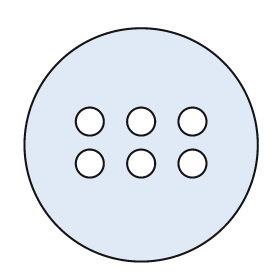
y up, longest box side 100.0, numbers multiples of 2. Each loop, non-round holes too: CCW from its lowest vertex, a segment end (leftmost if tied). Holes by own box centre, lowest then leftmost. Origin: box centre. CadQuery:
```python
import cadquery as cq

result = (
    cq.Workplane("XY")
    .moveTo(0.0, 0.0)
    .circle(50.0)
    .moveTo(-22.0, -8.0)
    .circle(6.0)
    .moveTo(0.0, -8.0)
    .circle(6.0)
    .moveTo(22.0, -8.0)
    .circle(6.0)
    .moveTo(-22.0, 10.0)
    .circle(6.0)
    .moveTo(0.0, 10.0)
    .circle(6.0)
    .moveTo(22.0, 10.0)
    .circle(6.0)
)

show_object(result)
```